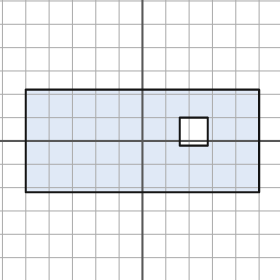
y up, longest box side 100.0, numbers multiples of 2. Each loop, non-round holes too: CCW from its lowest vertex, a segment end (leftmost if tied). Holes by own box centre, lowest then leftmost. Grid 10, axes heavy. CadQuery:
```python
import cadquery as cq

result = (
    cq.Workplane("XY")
    .moveTo(-50.0, -22.0)
    .lineTo(50.0, -22.0)
    .lineTo(50.0, 22.0)
    .lineTo(-50.0, 22.0)
    .close()
    .moveTo(16.0, -2.0)
    .lineTo(28.0, -2.0)
    .lineTo(28.0, 10.0)
    .lineTo(16.0, 10.0)
    .close()
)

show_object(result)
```